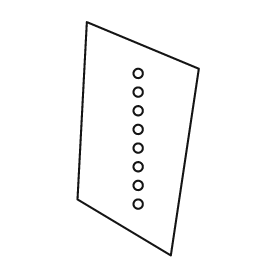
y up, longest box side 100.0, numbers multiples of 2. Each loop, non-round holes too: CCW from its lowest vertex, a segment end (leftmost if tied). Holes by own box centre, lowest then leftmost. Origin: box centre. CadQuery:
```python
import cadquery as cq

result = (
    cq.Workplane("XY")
    .moveTo(14.0, -50.0)
    .lineTo(26.0, 30.0)
    .lineTo(-22.0, 50.0)
    .lineTo(-26.0, -26.0)
    .close()
    .moveTo(0.0, -28.0)
    .circle(2.0)
    .moveTo(0.0, -20.0)
    .circle(2.0)
    .moveTo(0.0, -12.0)
    .circle(2.0)
    .moveTo(0.0, -4.0)
    .circle(2.0)
    .moveTo(0.0, 4.0)
    .circle(2.0)
    .moveTo(0.0, 12.0)
    .circle(2.0)
    .moveTo(0.0, 20.0)
    .circle(2.0)
    .moveTo(0.0, 28.0)
    .circle(2.0)
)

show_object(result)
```